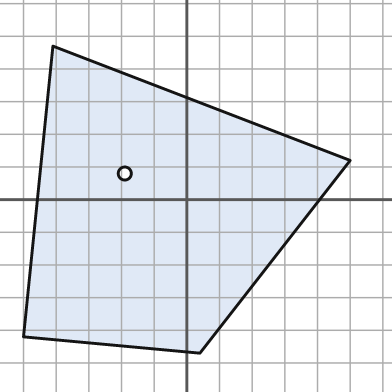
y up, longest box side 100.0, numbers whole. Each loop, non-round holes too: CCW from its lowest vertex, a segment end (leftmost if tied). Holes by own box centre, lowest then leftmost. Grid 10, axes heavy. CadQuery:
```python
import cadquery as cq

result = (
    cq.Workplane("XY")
    .moveTo(4.0, -47.0)
    .lineTo(50.0, 12.0)
    .lineTo(-41.0, 47.0)
    .lineTo(-50.0, -42.0)
    .close()
    .moveTo(-19.0, 8.0)
    .circle(2.0)
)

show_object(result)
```